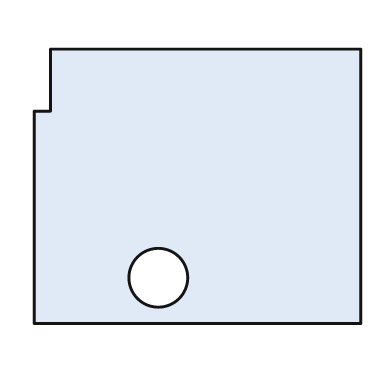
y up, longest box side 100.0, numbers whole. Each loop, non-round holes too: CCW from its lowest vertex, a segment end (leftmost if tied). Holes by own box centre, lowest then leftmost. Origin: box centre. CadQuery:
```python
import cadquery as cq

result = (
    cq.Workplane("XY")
    .moveTo(-50.0, -42.0)
    .lineTo(50.0, -42.0)
    .lineTo(50.0, 42.0)
    .lineTo(-45.0, 42.0)
    .lineTo(-45.0, 23.0)
    .lineTo(-50.0, 23.0)
    .close()
    .moveTo(-12.0, -28.0)
    .circle(9.0)
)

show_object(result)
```